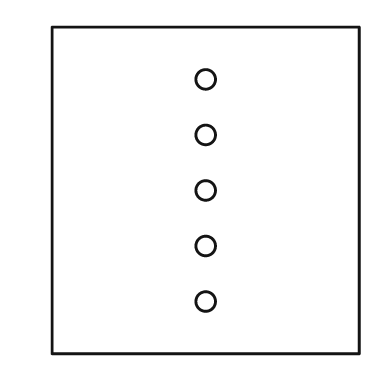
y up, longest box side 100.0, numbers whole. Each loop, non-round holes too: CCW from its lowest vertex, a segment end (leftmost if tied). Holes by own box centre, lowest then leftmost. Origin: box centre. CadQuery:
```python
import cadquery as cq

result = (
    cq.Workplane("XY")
    .moveTo(-47.0, -50.0)
    .lineTo(47.0, -50.0)
    .lineTo(47.0, 50.0)
    .lineTo(-47.0, 50.0)
    .close()
    .moveTo(0.0, -34.0)
    .circle(3.0)
    .moveTo(0.0, -17.0)
    .circle(3.0)
    .moveTo(0.0, 0.0)
    .circle(3.0)
    .moveTo(0.0, 17.0)
    .circle(3.0)
    .moveTo(0.0, 34.0)
    .circle(3.0)
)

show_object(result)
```